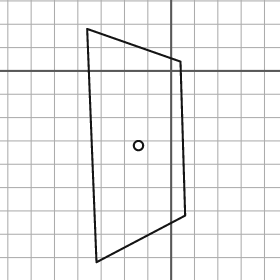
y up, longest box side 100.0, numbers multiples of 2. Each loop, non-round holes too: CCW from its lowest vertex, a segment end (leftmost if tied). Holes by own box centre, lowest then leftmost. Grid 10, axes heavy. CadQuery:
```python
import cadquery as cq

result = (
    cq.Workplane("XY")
    .moveTo(-32.0, -82.0)
    .lineTo(6.0, -62.0)
    .lineTo(4.0, 4.0)
    .lineTo(-36.0, 18.0)
    .close()
    .moveTo(-14.0, -32.0)
    .circle(2.0)
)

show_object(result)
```